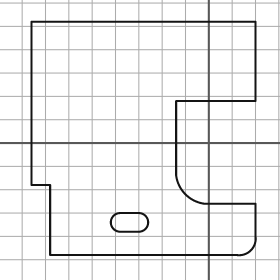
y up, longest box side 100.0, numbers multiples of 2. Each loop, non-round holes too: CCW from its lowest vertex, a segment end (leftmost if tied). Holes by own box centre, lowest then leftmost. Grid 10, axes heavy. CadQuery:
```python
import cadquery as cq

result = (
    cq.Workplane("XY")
    .moveTo(-68.0, -48.0)
    .lineTo(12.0, -48.0)
    .threePointArc((18.0, -46.0), (20.0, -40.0))
    .lineTo(20.0, -26.0)
    .lineTo(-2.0, -26.0)
    .threePointArc((-10.0, -22.0), (-14.0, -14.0))
    .lineTo(-14.0, 18.0)
    .lineTo(20.0, 18.0)
    .lineTo(20.0, 52.0)
    .lineTo(-76.0, 52.0)
    .lineTo(-76.0, -18.0)
    .lineTo(-68.0, -18.0)
    .close()
    .moveTo(-38.0, -38.0)
    .lineTo(-30.0, -38.0)
    .threePointArc((-26.0, -34.0), (-30.0, -30.0))
    .lineTo(-38.0, -30.0)
    .threePointArc((-42.0, -34.0), (-38.0, -38.0))
    .close()
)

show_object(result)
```